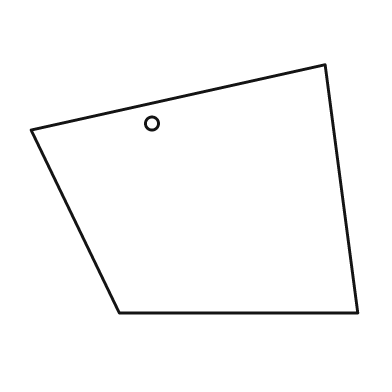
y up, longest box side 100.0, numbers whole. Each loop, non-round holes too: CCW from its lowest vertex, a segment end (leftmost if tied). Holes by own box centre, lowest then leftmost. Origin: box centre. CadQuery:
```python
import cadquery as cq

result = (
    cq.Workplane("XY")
    .moveTo(-23.0, -38.0)
    .lineTo(50.0, -38.0)
    .lineTo(40.0, 38.0)
    .lineTo(-50.0, 18.0)
    .close()
    .moveTo(-13.0, 20.0)
    .circle(2.0)
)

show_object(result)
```